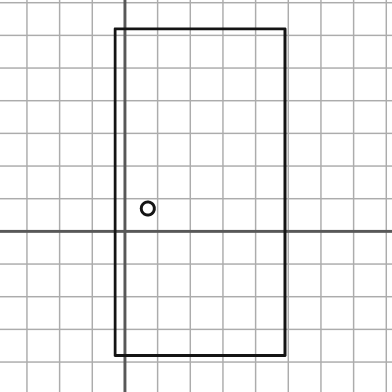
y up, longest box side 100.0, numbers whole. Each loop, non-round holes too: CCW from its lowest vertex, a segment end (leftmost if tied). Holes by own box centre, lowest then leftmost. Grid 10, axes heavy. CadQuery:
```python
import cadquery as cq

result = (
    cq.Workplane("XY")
    .moveTo(-3.0, -38.0)
    .lineTo(49.0, -38.0)
    .lineTo(49.0, 62.0)
    .lineTo(-3.0, 62.0)
    .close()
    .moveTo(7.0, 7.0)
    .circle(2.0)
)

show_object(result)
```